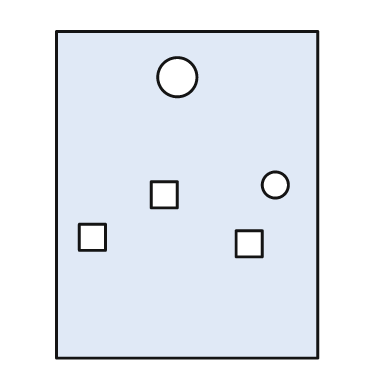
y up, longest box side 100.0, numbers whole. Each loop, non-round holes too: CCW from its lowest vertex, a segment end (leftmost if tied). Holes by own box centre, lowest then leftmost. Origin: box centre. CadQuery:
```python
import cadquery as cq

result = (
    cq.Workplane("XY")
    .moveTo(-40.0, -50.0)
    .lineTo(40.0, -50.0)
    .lineTo(40.0, 50.0)
    .lineTo(-40.0, 50.0)
    .close()
    .moveTo(15.0, -19.0)
    .lineTo(23.0, -19.0)
    .lineTo(23.0, -11.0)
    .lineTo(15.0, -11.0)
    .close()
    .moveTo(-33.0, -17.0)
    .lineTo(-25.0, -17.0)
    .lineTo(-25.0, -9.0)
    .lineTo(-33.0, -9.0)
    .close()
    .moveTo(-11.0, -4.0)
    .lineTo(-3.0, -4.0)
    .lineTo(-3.0, 4.0)
    .lineTo(-11.0, 4.0)
    .close()
    .moveTo(27.0, 3.0)
    .circle(4.0)
    .moveTo(-3.0, 36.0)
    .circle(6.0)
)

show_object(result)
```